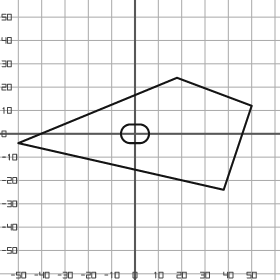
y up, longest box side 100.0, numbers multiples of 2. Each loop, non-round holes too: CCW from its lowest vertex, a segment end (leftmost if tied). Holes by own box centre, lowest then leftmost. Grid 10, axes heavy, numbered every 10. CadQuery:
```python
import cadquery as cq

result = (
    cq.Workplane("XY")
    .moveTo(38.0, -24.0)
    .lineTo(50.0, 12.0)
    .lineTo(18.0, 24.0)
    .lineTo(-50.0, -4.0)
    .close()
    .moveTo(-2.0, -4.0)
    .lineTo(2.0, -4.0)
    .threePointArc((6.0, 0.0), (2.0, 4.0))
    .lineTo(-2.0, 4.0)
    .threePointArc((-6.0, 0.0), (-2.0, -4.0))
    .close()
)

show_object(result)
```